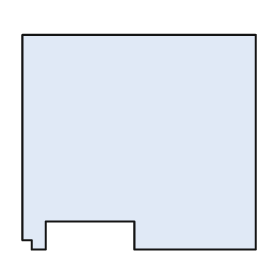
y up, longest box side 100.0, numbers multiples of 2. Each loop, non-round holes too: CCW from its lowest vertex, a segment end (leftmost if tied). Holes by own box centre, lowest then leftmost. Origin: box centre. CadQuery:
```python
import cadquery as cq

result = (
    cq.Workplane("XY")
    .moveTo(-46.0, -46.0)
    .lineTo(-40.0, -46.0)
    .lineTo(-40.0, -34.0)
    .lineTo(-2.0, -34.0)
    .lineTo(-2.0, -46.0)
    .lineTo(50.0, -46.0)
    .lineTo(50.0, 46.0)
    .lineTo(-50.0, 46.0)
    .lineTo(-50.0, -42.0)
    .lineTo(-46.0, -42.0)
    .close()
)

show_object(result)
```